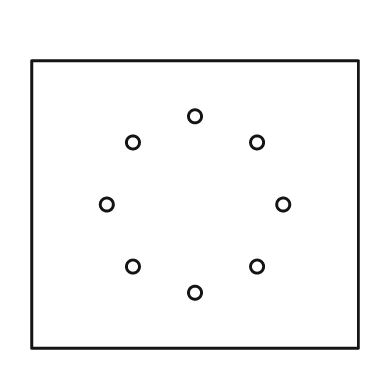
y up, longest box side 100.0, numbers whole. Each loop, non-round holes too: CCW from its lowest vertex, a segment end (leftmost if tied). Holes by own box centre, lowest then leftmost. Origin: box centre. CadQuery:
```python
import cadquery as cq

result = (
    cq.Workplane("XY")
    .moveTo(-50.0, -44.0)
    .lineTo(50.0, -44.0)
    .lineTo(50.0, 44.0)
    .lineTo(-50.0, 44.0)
    .close()
    .moveTo(0.0, -27.0)
    .circle(2.0)
    .moveTo(-19.0, -19.0)
    .circle(2.0)
    .moveTo(19.0, -19.0)
    .circle(2.0)
    .moveTo(-27.0, 0.0)
    .circle(2.0)
    .moveTo(27.0, 0.0)
    .circle(2.0)
    .moveTo(-19.0, 19.0)
    .circle(2.0)
    .moveTo(19.0, 19.0)
    .circle(2.0)
    .moveTo(0.0, 27.0)
    .circle(2.0)
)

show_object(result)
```